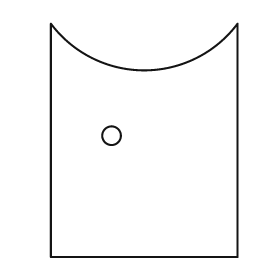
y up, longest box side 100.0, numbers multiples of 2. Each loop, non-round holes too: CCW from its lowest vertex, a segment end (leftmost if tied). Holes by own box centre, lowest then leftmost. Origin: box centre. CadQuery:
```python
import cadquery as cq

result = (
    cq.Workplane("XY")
    .moveTo(-40.0, -50.0)
    .lineTo(40.0, -50.0)
    .lineTo(40.0, 50.0)
    .threePointArc((0.0, 30.0), (-40.0, 50.0))
    .close()
    .moveTo(-14.0, 2.0)
    .circle(4.0)
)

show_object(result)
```